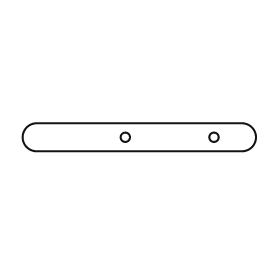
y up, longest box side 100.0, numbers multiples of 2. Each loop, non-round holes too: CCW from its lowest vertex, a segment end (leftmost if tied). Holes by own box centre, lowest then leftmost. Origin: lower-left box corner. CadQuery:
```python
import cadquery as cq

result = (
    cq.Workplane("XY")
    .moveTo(6.0, 0.0)
    .lineTo(94.0, 0.0)
    .threePointArc((100.0, 6.0), (94.0, 12.0))
    .lineTo(6.0, 12.0)
    .threePointArc((0.0, 6.0), (6.0, 0.0))
    .close()
    .moveTo(44.0, 6.0)
    .circle(2.0)
    .moveTo(82.0, 6.0)
    .circle(2.0)
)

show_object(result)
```